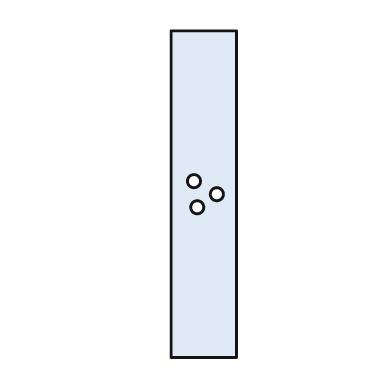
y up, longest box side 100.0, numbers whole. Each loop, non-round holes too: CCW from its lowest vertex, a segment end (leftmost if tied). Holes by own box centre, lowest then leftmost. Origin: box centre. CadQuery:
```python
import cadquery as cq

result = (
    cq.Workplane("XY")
    .moveTo(-10.0, -50.0)
    .lineTo(10.0, -50.0)
    .lineTo(10.0, 50.0)
    .lineTo(-10.0, 50.0)
    .close()
    .moveTo(-2.0, -4.0)
    .circle(2.0)
    .moveTo(4.0, 0.0)
    .circle(2.0)
    .moveTo(-3.0, 4.0)
    .circle(2.0)
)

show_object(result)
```